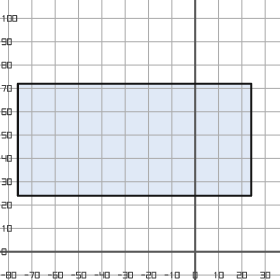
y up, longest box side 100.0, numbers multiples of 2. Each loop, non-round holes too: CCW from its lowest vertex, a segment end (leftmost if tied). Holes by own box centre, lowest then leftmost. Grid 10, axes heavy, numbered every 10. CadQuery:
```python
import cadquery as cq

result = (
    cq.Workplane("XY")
    .moveTo(-76.0, 24.0)
    .lineTo(24.0, 24.0)
    .lineTo(24.0, 72.0)
    .lineTo(-76.0, 72.0)
    .close()
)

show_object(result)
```